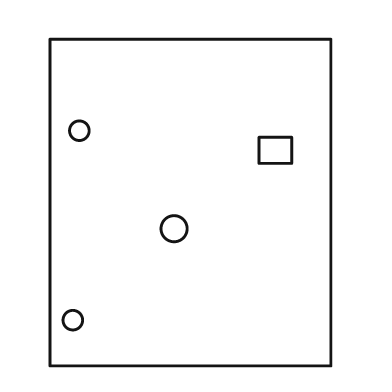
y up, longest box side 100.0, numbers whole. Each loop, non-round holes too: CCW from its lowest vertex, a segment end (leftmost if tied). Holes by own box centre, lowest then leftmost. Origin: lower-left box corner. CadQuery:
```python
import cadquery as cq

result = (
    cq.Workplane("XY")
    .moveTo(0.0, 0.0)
    .lineTo(86.0, 0.0)
    .lineTo(86.0, 100.0)
    .lineTo(0.0, 100.0)
    .close()
    .moveTo(7.0, 14.0)
    .circle(3.0)
    .moveTo(38.0, 42.0)
    .circle(4.0)
    .moveTo(64.0, 62.0)
    .lineTo(74.0, 62.0)
    .lineTo(74.0, 70.0)
    .lineTo(64.0, 70.0)
    .close()
    .moveTo(9.0, 72.0)
    .circle(3.0)
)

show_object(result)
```